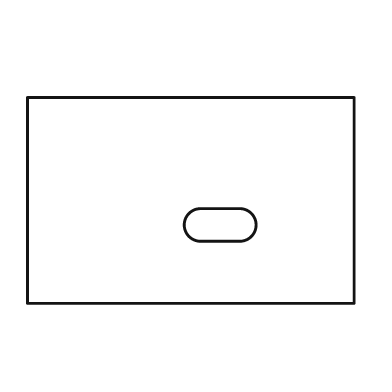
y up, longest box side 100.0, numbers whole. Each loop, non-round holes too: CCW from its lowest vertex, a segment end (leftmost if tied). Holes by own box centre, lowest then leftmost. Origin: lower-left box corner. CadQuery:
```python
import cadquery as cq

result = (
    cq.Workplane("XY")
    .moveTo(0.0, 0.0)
    .lineTo(100.0, 0.0)
    .lineTo(100.0, 63.0)
    .lineTo(0.0, 63.0)
    .close()
    .moveTo(53.0, 19.0)
    .lineTo(65.0, 19.0)
    .threePointArc((70.0, 24.0), (65.0, 29.0))
    .lineTo(53.0, 29.0)
    .threePointArc((48.0, 24.0), (53.0, 19.0))
    .close()
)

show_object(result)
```